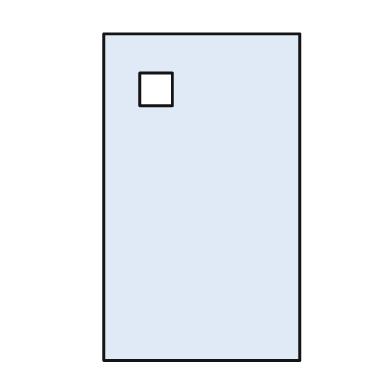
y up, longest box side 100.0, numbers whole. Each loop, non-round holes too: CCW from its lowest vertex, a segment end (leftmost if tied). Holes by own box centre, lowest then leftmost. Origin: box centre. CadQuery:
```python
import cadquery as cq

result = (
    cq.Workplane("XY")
    .moveTo(-30.0, -50.0)
    .lineTo(30.0, -50.0)
    .lineTo(30.0, 50.0)
    .lineTo(-30.0, 50.0)
    .close()
    .moveTo(-19.0, 28.0)
    .lineTo(-9.0, 28.0)
    .lineTo(-9.0, 38.0)
    .lineTo(-19.0, 38.0)
    .close()
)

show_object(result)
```